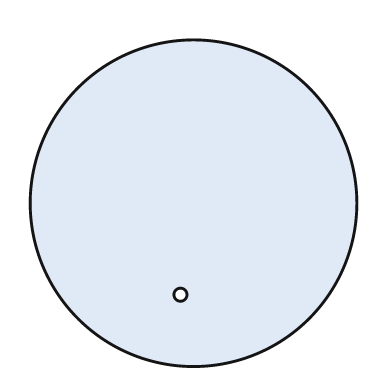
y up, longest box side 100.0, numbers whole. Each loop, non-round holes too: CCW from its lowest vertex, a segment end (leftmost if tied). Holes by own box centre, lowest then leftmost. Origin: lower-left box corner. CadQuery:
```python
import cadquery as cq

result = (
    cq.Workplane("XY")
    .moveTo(50.0, 50.0)
    .circle(50.0)
    .moveTo(46.0, 22.0)
    .circle(2.0)
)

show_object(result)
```